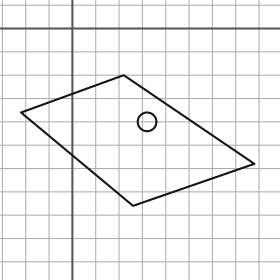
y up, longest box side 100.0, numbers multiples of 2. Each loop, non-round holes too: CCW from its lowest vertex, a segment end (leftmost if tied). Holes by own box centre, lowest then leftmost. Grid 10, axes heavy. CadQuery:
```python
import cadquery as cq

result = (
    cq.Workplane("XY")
    .moveTo(26.0, -76.0)
    .lineTo(78.0, -58.0)
    .lineTo(22.0, -20.0)
    .lineTo(-22.0, -36.0)
    .close()
    .moveTo(32.0, -40.0)
    .circle(4.0)
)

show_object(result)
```